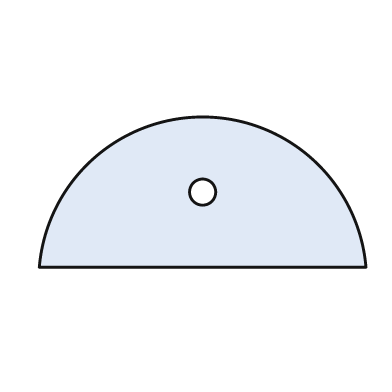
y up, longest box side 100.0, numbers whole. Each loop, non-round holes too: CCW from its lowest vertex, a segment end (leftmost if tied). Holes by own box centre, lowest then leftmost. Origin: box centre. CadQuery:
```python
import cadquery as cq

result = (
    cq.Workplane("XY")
    .moveTo(-50.0, -23.0)
    .lineTo(50.0, -23.0)
    .threePointArc((0.0, 23.0), (-50.0, -23.0))
    .close()
    .moveTo(0.0, 0.0)
    .circle(4.0)
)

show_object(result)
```